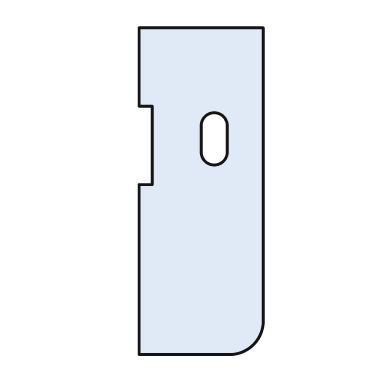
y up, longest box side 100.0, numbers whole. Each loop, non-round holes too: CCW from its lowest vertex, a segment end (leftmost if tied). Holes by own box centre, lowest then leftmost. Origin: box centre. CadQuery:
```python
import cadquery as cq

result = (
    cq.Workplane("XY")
    .moveTo(-19.0, -50.0)
    .lineTo(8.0, -50.0)
    .threePointArc((16.0, -47.0), (19.0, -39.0))
    .lineTo(19.0, 50.0)
    .lineTo(-19.0, 50.0)
    .lineTo(-19.0, 26.0)
    .lineTo(-15.0, 26.0)
    .lineTo(-15.0, 2.0)
    .lineTo(-19.0, 2.0)
    .close()
    .moveTo(0.0, 12.0)
    .threePointArc((4.0, 8.0), (8.0, 12.0))
    .lineTo(8.0, 20.0)
    .threePointArc((4.0, 24.0), (0.0, 20.0))
    .close()
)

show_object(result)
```